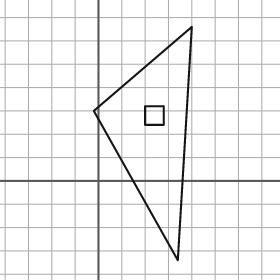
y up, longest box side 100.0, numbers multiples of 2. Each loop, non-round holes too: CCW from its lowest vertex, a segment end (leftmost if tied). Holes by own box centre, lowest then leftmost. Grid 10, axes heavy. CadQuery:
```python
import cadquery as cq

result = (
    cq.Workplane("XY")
    .moveTo(34.0, -34.0)
    .lineTo(40.0, 66.0)
    .lineTo(-2.0, 30.0)
    .close()
    .moveTo(20.0, 24.0)
    .lineTo(28.0, 24.0)
    .lineTo(28.0, 32.0)
    .lineTo(20.0, 32.0)
    .close()
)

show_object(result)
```